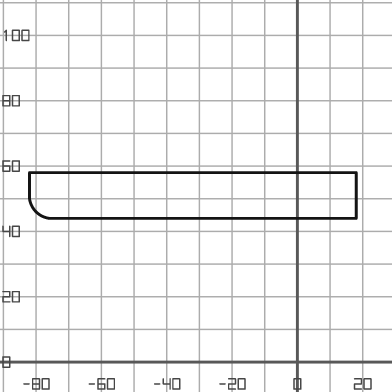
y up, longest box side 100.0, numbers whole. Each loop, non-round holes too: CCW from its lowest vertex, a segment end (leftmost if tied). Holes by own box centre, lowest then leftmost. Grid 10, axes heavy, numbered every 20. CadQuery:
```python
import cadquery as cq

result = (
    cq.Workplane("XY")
    .moveTo(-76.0, 44.0)
    .lineTo(18.0, 44.0)
    .lineTo(18.0, 58.0)
    .lineTo(-82.0, 58.0)
    .lineTo(-82.0, 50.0)
    .threePointArc((-80.0, 46.0), (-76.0, 44.0))
    .close()
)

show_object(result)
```